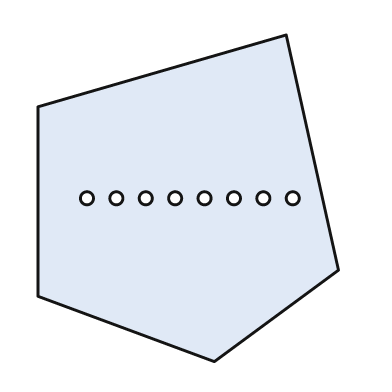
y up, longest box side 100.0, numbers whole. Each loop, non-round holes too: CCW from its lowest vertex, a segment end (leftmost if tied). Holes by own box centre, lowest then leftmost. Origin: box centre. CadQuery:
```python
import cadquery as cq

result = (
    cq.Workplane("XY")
    .moveTo(8.0, -50.0)
    .lineTo(46.0, -22.0)
    .lineTo(30.0, 50.0)
    .lineTo(-46.0, 28.0)
    .lineTo(-46.0, -30.0)
    .close()
    .moveTo(-31.0, 0.0)
    .circle(2.0)
    .moveTo(-22.0, 0.0)
    .circle(2.0)
    .moveTo(-13.0, 0.0)
    .circle(2.0)
    .moveTo(-4.0, 0.0)
    .circle(2.0)
    .moveTo(5.0, 0.0)
    .circle(2.0)
    .moveTo(14.0, 0.0)
    .circle(2.0)
    .moveTo(23.0, 0.0)
    .circle(2.0)
    .moveTo(32.0, 0.0)
    .circle(2.0)
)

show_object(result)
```